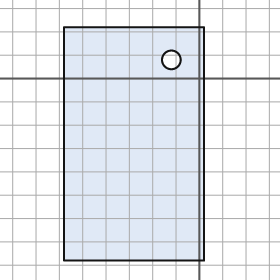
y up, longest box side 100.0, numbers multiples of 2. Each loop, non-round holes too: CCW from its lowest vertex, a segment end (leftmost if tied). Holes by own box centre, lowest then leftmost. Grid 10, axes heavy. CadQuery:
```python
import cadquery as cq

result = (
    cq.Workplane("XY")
    .moveTo(-58.0, -78.0)
    .lineTo(2.0, -78.0)
    .lineTo(2.0, 22.0)
    .lineTo(-58.0, 22.0)
    .close()
    .moveTo(-12.0, 8.0)
    .circle(4.0)
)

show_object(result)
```